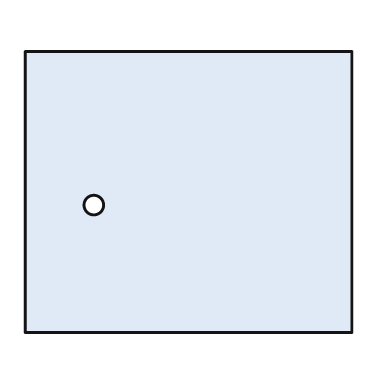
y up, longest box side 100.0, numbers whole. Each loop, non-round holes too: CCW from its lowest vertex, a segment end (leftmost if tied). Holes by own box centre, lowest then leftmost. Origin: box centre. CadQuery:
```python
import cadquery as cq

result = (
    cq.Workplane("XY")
    .moveTo(-50.0, -43.0)
    .lineTo(50.0, -43.0)
    .lineTo(50.0, 43.0)
    .lineTo(-50.0, 43.0)
    .close()
    .moveTo(-29.0, -4.0)
    .circle(3.0)
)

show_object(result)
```